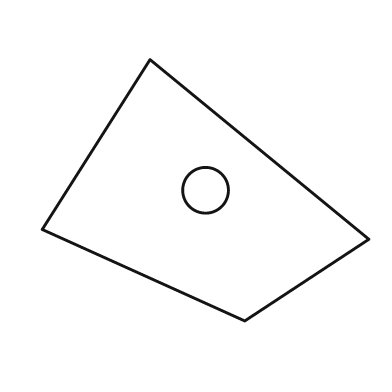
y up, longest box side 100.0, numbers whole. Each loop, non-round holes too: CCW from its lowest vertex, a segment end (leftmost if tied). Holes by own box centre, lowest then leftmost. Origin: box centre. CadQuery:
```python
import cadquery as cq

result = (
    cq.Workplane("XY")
    .moveTo(12.0, -40.0)
    .lineTo(50.0, -15.0)
    .lineTo(-17.0, 40.0)
    .lineTo(-50.0, -12.0)
    .close()
    .moveTo(0.0, 0.0)
    .circle(7.0)
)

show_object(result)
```